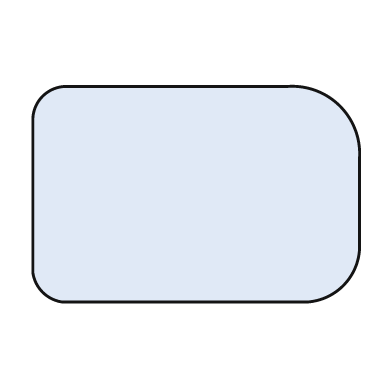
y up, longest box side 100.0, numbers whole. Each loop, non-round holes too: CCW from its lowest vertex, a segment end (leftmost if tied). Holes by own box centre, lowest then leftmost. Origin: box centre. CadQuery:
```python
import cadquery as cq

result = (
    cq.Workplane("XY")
    .moveTo(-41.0, -33.0)
    .lineTo(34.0, -33.0)
    .threePointArc((45.0, -28.0), (50.0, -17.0))
    .lineTo(50.0, 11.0)
    .threePointArc((44.0, 27.0), (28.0, 33.0))
    .lineTo(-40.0, 33.0)
    .threePointArc((-47.0, 30.0), (-50.0, 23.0))
    .lineTo(-50.0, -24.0)
    .threePointArc((-47.0, -30.0), (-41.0, -33.0))
    .close()
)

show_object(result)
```